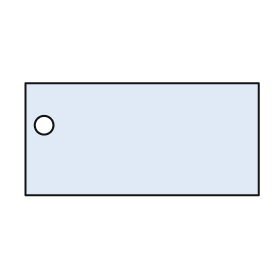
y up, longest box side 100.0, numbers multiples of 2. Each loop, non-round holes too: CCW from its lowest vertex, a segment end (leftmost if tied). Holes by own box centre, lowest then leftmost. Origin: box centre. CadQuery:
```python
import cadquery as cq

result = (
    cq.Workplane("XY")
    .moveTo(-50.0, -24.0)
    .lineTo(50.0, -24.0)
    .lineTo(50.0, 24.0)
    .lineTo(-50.0, 24.0)
    .close()
    .moveTo(-42.0, 6.0)
    .circle(4.0)
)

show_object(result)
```